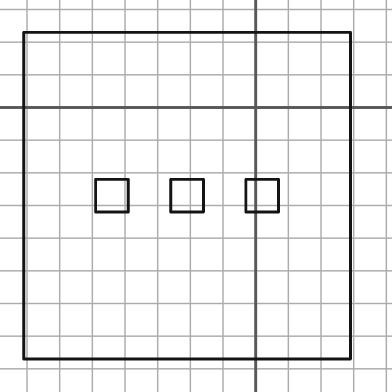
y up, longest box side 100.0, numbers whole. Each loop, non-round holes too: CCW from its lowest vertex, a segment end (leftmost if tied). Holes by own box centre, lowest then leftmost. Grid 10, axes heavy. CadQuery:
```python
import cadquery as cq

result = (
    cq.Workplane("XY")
    .moveTo(-71.0, -77.0)
    .lineTo(29.0, -77.0)
    .lineTo(29.0, 23.0)
    .lineTo(-71.0, 23.0)
    .close()
    .moveTo(-49.0, -32.0)
    .lineTo(-39.0, -32.0)
    .lineTo(-39.0, -22.0)
    .lineTo(-49.0, -22.0)
    .close()
    .moveTo(-26.0, -32.0)
    .lineTo(-16.0, -32.0)
    .lineTo(-16.0, -22.0)
    .lineTo(-26.0, -22.0)
    .close()
    .moveTo(-3.0, -32.0)
    .lineTo(7.0, -32.0)
    .lineTo(7.0, -22.0)
    .lineTo(-3.0, -22.0)
    .close()
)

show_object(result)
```